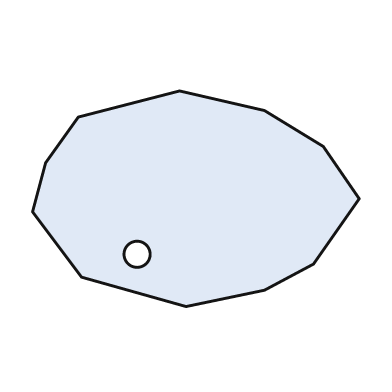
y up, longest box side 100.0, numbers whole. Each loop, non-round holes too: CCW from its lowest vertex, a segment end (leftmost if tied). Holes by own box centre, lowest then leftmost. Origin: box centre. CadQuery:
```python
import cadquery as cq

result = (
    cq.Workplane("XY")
    .moveTo(-3.0, -33.0)
    .lineTo(21.0, -28.0)
    .lineTo(36.0, -20.0)
    .lineTo(50.0, 0.0)
    .lineTo(39.0, 16.0)
    .lineTo(21.0, 27.0)
    .lineTo(-5.0, 33.0)
    .lineTo(-36.0, 25.0)
    .lineTo(-46.0, 11.0)
    .lineTo(-50.0, -4.0)
    .lineTo(-35.0, -24.0)
    .close()
    .moveTo(-18.0, -17.0)
    .circle(4.0)
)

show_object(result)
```